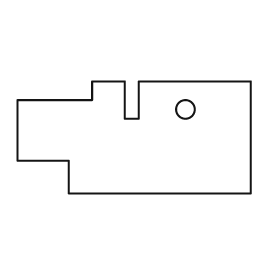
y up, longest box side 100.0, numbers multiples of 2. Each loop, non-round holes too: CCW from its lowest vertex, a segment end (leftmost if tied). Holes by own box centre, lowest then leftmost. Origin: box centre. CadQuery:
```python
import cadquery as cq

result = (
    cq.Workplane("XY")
    .moveTo(-28.0, -24.0)
    .lineTo(50.0, -24.0)
    .lineTo(50.0, 24.0)
    .lineTo(2.0, 24.0)
    .lineTo(2.0, 8.0)
    .lineTo(-4.0, 8.0)
    .lineTo(-4.0, 24.0)
    .lineTo(-18.0, 24.0)
    .lineTo(-18.0, 16.0)
    .lineTo(-50.0, 16.0)
    .lineTo(-50.0, -10.0)
    .lineTo(-28.0, -10.0)
    .close()
    .moveTo(22.0, 12.0)
    .circle(4.0)
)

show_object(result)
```